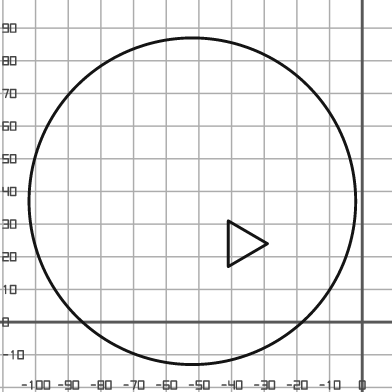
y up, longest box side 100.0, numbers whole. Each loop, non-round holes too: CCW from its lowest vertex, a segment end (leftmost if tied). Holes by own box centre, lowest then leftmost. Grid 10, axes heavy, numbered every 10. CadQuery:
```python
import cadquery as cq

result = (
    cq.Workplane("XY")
    .moveTo(-52.0, 37.0)
    .circle(50.0)
    .moveTo(-41.0, 17.0)
    .lineTo(-29.0, 24.0)
    .lineTo(-41.0, 31.0)
    .close()
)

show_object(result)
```